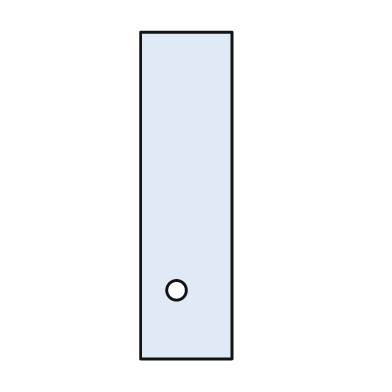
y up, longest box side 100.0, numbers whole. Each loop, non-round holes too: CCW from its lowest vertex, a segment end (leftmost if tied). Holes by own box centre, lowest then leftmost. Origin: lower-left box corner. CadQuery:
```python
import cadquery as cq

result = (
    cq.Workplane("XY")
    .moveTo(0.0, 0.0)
    .lineTo(28.0, 0.0)
    .lineTo(28.0, 100.0)
    .lineTo(0.0, 100.0)
    .close()
    .moveTo(11.0, 21.0)
    .circle(3.0)
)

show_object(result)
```